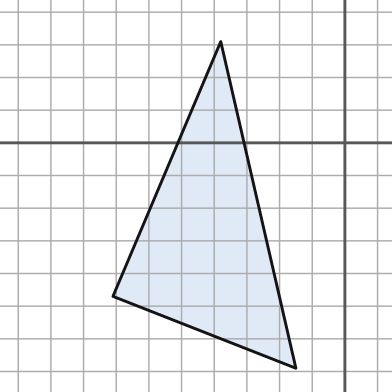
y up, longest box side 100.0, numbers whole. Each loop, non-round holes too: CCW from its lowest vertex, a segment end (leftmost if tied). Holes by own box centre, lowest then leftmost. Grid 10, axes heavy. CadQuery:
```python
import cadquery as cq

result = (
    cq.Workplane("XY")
    .moveTo(-15.0, -69.0)
    .lineTo(-38.0, 31.0)
    .lineTo(-71.0, -47.0)
    .close()
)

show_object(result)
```